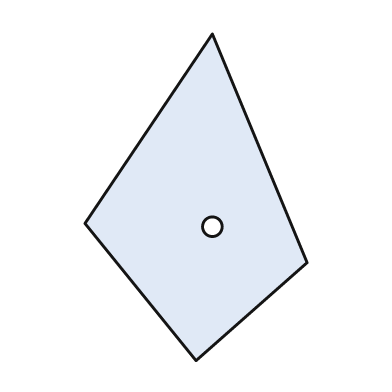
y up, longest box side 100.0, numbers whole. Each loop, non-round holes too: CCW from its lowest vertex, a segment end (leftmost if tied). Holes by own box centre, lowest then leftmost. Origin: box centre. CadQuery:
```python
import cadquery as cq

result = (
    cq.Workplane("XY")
    .moveTo(0.0, -50.0)
    .lineTo(34.0, -20.0)
    .lineTo(5.0, 50.0)
    .lineTo(-34.0, -8.0)
    .close()
    .moveTo(5.0, -9.0)
    .circle(3.0)
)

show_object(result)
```